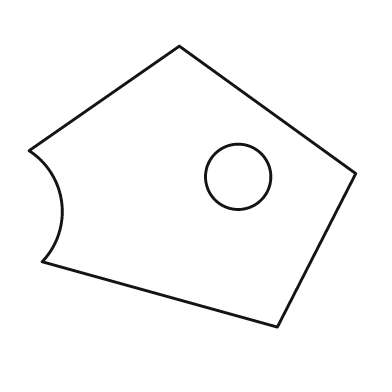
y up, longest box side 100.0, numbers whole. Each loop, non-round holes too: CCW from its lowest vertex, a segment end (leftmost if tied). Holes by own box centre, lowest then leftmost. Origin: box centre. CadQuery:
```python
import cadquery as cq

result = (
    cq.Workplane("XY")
    .moveTo(26.0, -43.0)
    .lineTo(50.0, 4.0)
    .lineTo(-4.0, 43.0)
    .lineTo(-50.0, 11.0)
    .threePointArc((-40.0, -5.0), (-46.0, -23.0))
    .close()
    .moveTo(14.0, 3.0)
    .circle(10.0)
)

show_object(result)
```